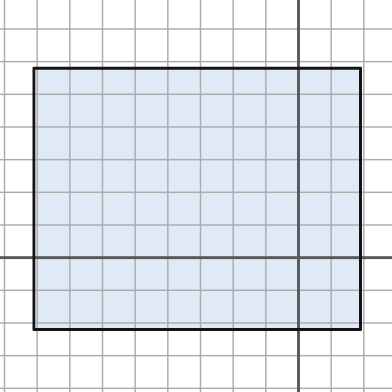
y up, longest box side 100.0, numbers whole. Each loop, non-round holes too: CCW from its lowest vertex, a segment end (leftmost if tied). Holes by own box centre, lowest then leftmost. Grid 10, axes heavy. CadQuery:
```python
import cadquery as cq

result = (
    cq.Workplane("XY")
    .moveTo(-81.0, -22.0)
    .lineTo(19.0, -22.0)
    .lineTo(19.0, 58.0)
    .lineTo(-81.0, 58.0)
    .close()
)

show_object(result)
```